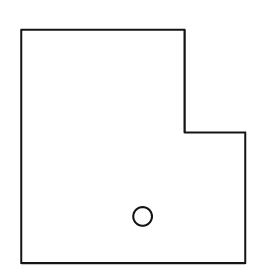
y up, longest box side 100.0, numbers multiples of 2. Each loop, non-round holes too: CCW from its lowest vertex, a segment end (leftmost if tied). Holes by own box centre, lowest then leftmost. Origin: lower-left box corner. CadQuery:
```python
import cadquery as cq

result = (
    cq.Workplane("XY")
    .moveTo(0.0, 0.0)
    .lineTo(96.0, 0.0)
    .lineTo(96.0, 56.0)
    .lineTo(70.0, 56.0)
    .lineTo(70.0, 100.0)
    .lineTo(0.0, 100.0)
    .close()
    .moveTo(52.0, 20.0)
    .circle(4.0)
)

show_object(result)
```